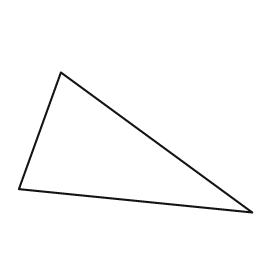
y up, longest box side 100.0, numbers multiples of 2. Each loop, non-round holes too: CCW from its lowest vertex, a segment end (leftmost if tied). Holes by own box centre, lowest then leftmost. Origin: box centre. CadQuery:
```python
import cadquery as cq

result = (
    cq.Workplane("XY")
    .moveTo(50.0, -30.0)
    .lineTo(-32.0, 30.0)
    .lineTo(-50.0, -20.0)
    .close()
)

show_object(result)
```